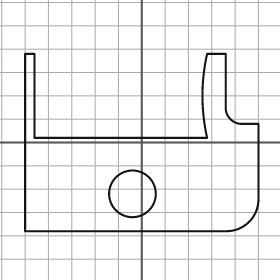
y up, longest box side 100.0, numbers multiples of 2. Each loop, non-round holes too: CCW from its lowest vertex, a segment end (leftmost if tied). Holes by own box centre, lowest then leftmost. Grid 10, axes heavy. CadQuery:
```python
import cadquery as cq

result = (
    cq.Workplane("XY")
    .moveTo(-50.0, -38.0)
    .lineTo(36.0, -38.0)
    .threePointArc((46.0, -34.0), (50.0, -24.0))
    .lineTo(50.0, 8.0)
    .lineTo(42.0, 8.0)
    .threePointArc((38.0, 10.0), (36.0, 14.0))
    .lineTo(36.0, 38.0)
    .lineTo(28.0, 38.0)
    .threePointArc((26.0, 20.0), (28.0, 2.0))
    .lineTo(-46.0, 2.0)
    .lineTo(-46.0, 38.0)
    .lineTo(-50.0, 38.0)
    .close()
    .moveTo(-4.0, -22.0)
    .circle(10.0)
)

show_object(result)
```